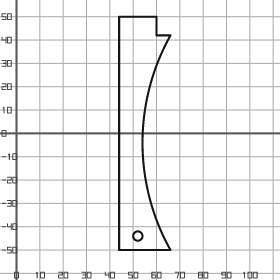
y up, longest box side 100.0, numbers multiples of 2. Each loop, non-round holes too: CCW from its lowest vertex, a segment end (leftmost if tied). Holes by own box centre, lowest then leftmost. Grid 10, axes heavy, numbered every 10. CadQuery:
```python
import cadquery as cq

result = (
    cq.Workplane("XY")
    .moveTo(44.0, -50.0)
    .lineTo(66.0, -50.0)
    .threePointArc((54.0, -4.0), (66.0, 42.0))
    .lineTo(60.0, 42.0)
    .lineTo(60.0, 50.0)
    .lineTo(44.0, 50.0)
    .close()
    .moveTo(52.0, -44.0)
    .circle(2.0)
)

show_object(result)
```